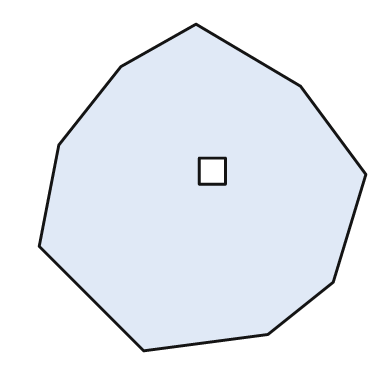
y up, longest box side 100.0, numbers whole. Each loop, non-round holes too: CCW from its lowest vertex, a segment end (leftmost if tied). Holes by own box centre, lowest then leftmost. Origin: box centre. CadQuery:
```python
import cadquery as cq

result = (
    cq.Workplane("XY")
    .moveTo(-18.0, -50.0)
    .lineTo(20.0, -45.0)
    .lineTo(40.0, -29.0)
    .lineTo(50.0, 4.0)
    .lineTo(30.0, 31.0)
    .lineTo(-2.0, 50.0)
    .lineTo(-25.0, 37.0)
    .lineTo(-44.0, 13.0)
    .lineTo(-50.0, -18.0)
    .close()
    .moveTo(-1.0, 1.0)
    .lineTo(7.0, 1.0)
    .lineTo(7.0, 9.0)
    .lineTo(-1.0, 9.0)
    .close()
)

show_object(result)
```